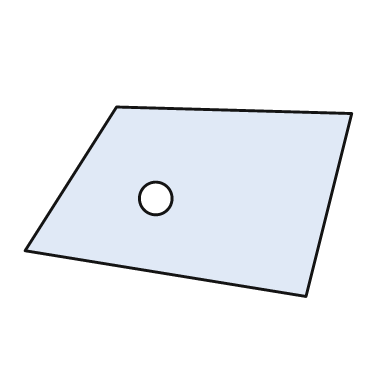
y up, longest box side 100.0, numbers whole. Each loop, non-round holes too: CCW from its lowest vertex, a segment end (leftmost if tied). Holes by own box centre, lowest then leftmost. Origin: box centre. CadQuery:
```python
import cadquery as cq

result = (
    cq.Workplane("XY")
    .moveTo(36.0, -29.0)
    .lineTo(50.0, 27.0)
    .lineTo(-22.0, 29.0)
    .lineTo(-50.0, -15.0)
    .close()
    .moveTo(-10.0, 1.0)
    .circle(5.0)
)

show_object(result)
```